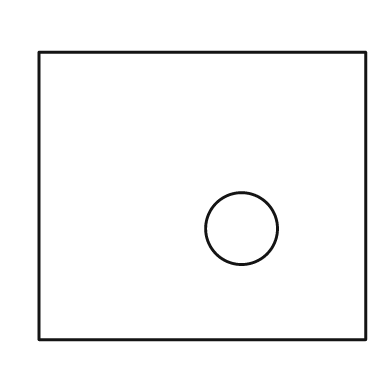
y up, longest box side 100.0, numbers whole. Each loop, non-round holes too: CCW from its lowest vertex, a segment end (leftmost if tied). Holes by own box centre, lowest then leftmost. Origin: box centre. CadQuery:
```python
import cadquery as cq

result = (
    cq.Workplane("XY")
    .moveTo(-50.0, -44.0)
    .lineTo(50.0, -44.0)
    .lineTo(50.0, 44.0)
    .lineTo(-50.0, 44.0)
    .close()
    .moveTo(12.0, -10.0)
    .circle(11.0)
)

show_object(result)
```